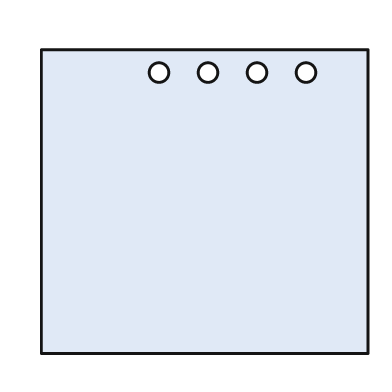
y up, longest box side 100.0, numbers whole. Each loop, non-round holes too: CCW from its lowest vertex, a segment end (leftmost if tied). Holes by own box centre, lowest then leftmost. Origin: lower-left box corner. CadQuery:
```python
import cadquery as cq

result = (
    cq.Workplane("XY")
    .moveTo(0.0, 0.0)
    .lineTo(100.0, 0.0)
    .lineTo(100.0, 93.0)
    .lineTo(0.0, 93.0)
    .close()
    .moveTo(36.0, 86.0)
    .circle(3.0)
    .moveTo(51.0, 86.0)
    .circle(3.0)
    .moveTo(66.0, 86.0)
    .circle(3.0)
    .moveTo(81.0, 86.0)
    .circle(3.0)
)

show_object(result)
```